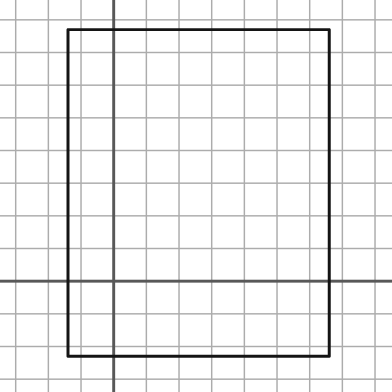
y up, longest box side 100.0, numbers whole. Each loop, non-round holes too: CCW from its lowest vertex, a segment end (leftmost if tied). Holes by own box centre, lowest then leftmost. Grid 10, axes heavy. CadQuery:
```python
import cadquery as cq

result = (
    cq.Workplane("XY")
    .moveTo(-14.0, -23.0)
    .lineTo(66.0, -23.0)
    .lineTo(66.0, 77.0)
    .lineTo(-14.0, 77.0)
    .close()
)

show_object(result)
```